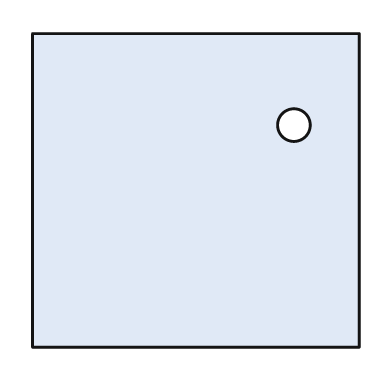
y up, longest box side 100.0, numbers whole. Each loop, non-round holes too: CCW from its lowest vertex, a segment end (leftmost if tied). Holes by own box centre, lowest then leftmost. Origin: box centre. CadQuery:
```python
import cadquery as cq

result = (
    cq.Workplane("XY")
    .moveTo(-50.0, -48.0)
    .lineTo(50.0, -48.0)
    .lineTo(50.0, 48.0)
    .lineTo(-50.0, 48.0)
    .close()
    .moveTo(30.0, 20.0)
    .circle(5.0)
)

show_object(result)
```